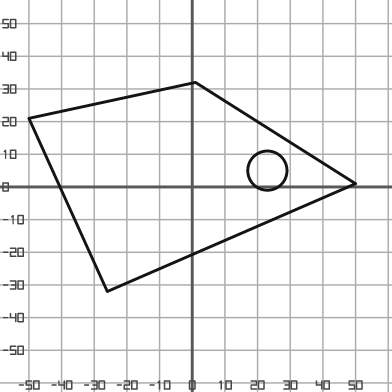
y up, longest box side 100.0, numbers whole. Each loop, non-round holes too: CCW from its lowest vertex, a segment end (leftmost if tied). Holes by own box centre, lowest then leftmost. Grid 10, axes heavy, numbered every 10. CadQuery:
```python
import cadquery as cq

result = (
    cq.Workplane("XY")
    .moveTo(-26.0, -32.0)
    .lineTo(50.0, 1.0)
    .lineTo(1.0, 32.0)
    .lineTo(-50.0, 21.0)
    .close()
    .moveTo(23.0, 5.0)
    .circle(6.0)
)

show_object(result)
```